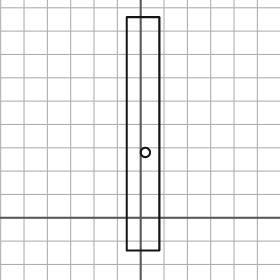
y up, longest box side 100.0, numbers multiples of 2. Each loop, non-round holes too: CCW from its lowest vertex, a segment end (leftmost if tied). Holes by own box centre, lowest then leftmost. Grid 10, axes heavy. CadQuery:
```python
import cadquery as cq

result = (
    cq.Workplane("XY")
    .moveTo(-6.0, -14.0)
    .lineTo(8.0, -14.0)
    .lineTo(8.0, 86.0)
    .lineTo(-6.0, 86.0)
    .close()
    .moveTo(2.0, 28.0)
    .circle(2.0)
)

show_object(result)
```